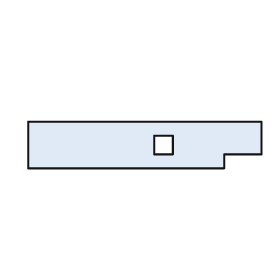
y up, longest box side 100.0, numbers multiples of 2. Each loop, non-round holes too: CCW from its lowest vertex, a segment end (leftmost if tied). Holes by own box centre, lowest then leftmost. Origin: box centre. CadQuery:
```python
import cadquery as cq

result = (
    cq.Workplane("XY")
    .moveTo(-50.0, -10.0)
    .lineTo(34.0, -10.0)
    .lineTo(34.0, -4.0)
    .lineTo(50.0, -4.0)
    .lineTo(50.0, 10.0)
    .lineTo(-50.0, 10.0)
    .close()
    .moveTo(4.0, -4.0)
    .lineTo(12.0, -4.0)
    .lineTo(12.0, 4.0)
    .lineTo(4.0, 4.0)
    .close()
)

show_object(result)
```